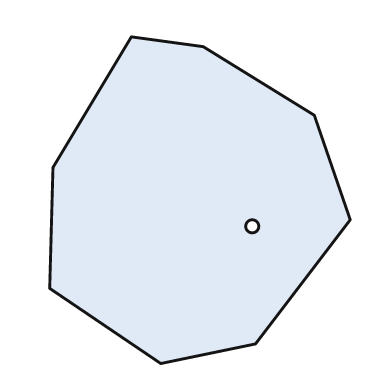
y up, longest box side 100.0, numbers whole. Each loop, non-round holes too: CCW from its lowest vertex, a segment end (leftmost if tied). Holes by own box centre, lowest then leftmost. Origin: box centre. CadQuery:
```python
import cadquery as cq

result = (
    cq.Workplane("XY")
    .moveTo(-12.0, -50.0)
    .lineTo(17.0, -44.0)
    .lineTo(46.0, -6.0)
    .lineTo(35.0, 26.0)
    .lineTo(1.0, 47.0)
    .lineTo(-21.0, 50.0)
    .lineTo(-45.0, 10.0)
    .lineTo(-46.0, -27.0)
    .close()
    .moveTo(16.0, -8.0)
    .circle(2.0)
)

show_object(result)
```